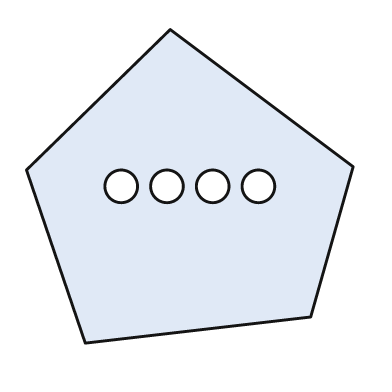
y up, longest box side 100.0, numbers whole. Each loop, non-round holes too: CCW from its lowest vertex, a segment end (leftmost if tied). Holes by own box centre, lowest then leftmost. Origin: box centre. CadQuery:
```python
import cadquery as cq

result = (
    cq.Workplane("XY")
    .moveTo(-32.0, -48.0)
    .lineTo(37.0, -40.0)
    .lineTo(50.0, 6.0)
    .lineTo(-6.0, 48.0)
    .lineTo(-50.0, 5.0)
    .close()
    .moveTo(-21.0, 0.0)
    .circle(5.0)
    .moveTo(-7.0, 0.0)
    .circle(5.0)
    .moveTo(7.0, 0.0)
    .circle(5.0)
    .moveTo(21.0, 0.0)
    .circle(5.0)
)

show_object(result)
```